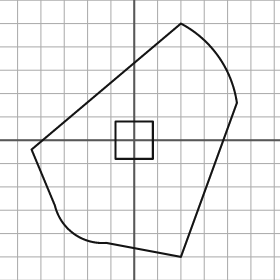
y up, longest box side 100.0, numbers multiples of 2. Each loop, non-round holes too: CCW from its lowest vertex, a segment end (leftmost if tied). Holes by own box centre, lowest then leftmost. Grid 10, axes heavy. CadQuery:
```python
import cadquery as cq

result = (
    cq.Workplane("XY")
    .moveTo(20.0, -50.0)
    .lineTo(44.0, 16.0)
    .threePointArc((36.0, 36.0), (20.0, 50.0))
    .lineTo(-44.0, -4.0)
    .lineTo(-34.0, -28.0)
    .threePointArc((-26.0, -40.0), (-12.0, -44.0))
    .close()
    .moveTo(-8.0, -8.0)
    .lineTo(8.0, -8.0)
    .lineTo(8.0, 8.0)
    .lineTo(-8.0, 8.0)
    .close()
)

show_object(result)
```